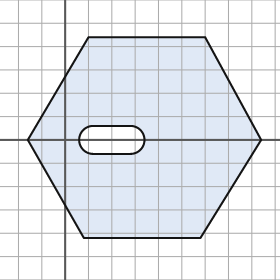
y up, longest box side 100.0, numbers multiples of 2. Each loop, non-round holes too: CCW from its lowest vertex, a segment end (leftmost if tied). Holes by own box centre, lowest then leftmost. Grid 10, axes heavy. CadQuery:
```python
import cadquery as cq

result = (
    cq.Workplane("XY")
    .moveTo(8.0, -42.0)
    .lineTo(58.0, -42.0)
    .lineTo(84.0, 0.0)
    .lineTo(60.0, 44.0)
    .lineTo(10.0, 44.0)
    .lineTo(-16.0, 0.0)
    .close()
    .moveTo(12.0, -6.0)
    .lineTo(28.0, -6.0)
    .threePointArc((34.0, 0.0), (28.0, 6.0))
    .lineTo(12.0, 6.0)
    .threePointArc((6.0, 0.0), (12.0, -6.0))
    .close()
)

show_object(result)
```